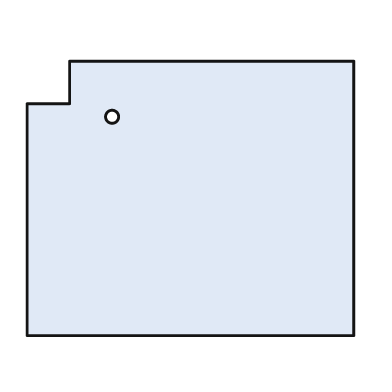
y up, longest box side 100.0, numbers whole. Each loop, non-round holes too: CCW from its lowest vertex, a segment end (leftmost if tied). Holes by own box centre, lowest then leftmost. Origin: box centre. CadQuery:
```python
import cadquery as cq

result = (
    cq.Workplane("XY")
    .moveTo(-50.0, -42.0)
    .lineTo(50.0, -42.0)
    .lineTo(50.0, 42.0)
    .lineTo(-37.0, 42.0)
    .lineTo(-37.0, 29.0)
    .lineTo(-50.0, 29.0)
    .close()
    .moveTo(-24.0, 25.0)
    .circle(2.0)
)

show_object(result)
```